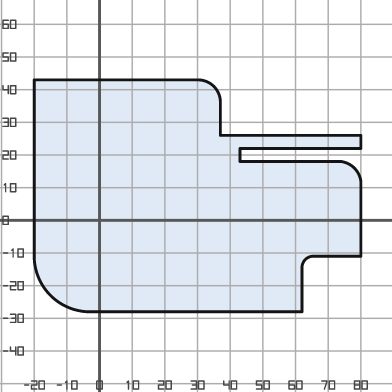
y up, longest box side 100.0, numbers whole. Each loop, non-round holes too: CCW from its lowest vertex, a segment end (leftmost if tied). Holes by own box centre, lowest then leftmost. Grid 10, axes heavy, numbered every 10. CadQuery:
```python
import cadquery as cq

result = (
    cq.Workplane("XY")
    .moveTo(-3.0, -28.0)
    .lineTo(62.0, -28.0)
    .lineTo(62.0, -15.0)
    .threePointArc((63.0, -12.0), (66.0, -11.0))
    .lineTo(80.0, -11.0)
    .lineTo(80.0, 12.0)
    .threePointArc((78.0, 16.0), (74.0, 18.0))
    .lineTo(43.0, 18.0)
    .lineTo(43.0, 22.0)
    .lineTo(80.0, 22.0)
    .lineTo(80.0, 26.0)
    .lineTo(37.0, 26.0)
    .lineTo(37.0, 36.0)
    .threePointArc((35.0, 41.0), (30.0, 43.0))
    .lineTo(-20.0, 43.0)
    .lineTo(-20.0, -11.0)
    .threePointArc((-15.0, -23.0), (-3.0, -28.0))
    .close()
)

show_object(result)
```